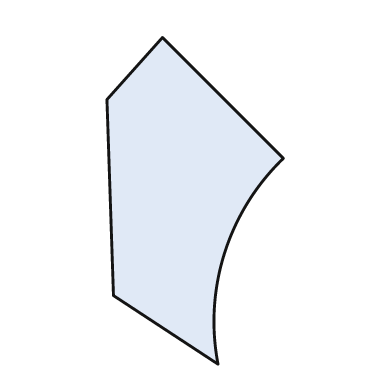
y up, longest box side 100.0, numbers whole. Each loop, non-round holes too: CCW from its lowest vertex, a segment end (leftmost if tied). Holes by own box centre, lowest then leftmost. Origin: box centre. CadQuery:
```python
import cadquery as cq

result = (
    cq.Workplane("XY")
    .moveTo(7.0, -50.0)
    .threePointArc((9.0, -16.0), (27.0, 13.0))
    .lineTo(-10.0, 50.0)
    .lineTo(-27.0, 31.0)
    .lineTo(-25.0, -29.0)
    .close()
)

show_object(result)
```